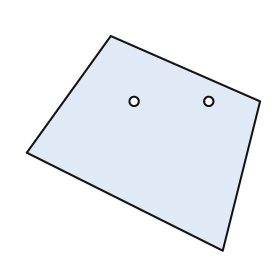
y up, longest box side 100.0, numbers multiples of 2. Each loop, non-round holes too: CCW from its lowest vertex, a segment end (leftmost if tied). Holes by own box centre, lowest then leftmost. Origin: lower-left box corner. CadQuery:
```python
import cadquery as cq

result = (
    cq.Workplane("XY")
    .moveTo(84.0, 0.0)
    .lineTo(100.0, 64.0)
    .lineTo(36.0, 92.0)
    .lineTo(0.0, 42.0)
    .close()
    .moveTo(46.0, 64.0)
    .circle(2.0)
    .moveTo(78.0, 64.0)
    .circle(2.0)
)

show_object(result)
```